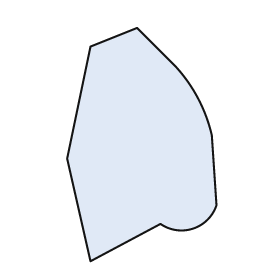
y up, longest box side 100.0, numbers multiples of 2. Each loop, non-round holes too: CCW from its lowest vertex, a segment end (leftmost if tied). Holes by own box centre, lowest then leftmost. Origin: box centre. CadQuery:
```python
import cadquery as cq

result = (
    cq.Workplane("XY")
    .moveTo(-22.0, -50.0)
    .lineTo(8.0, -34.0)
    .threePointArc((22.0, -36.0), (32.0, -26.0))
    .lineTo(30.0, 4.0)
    .threePointArc((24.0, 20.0), (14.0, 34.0))
    .lineTo(-2.0, 50.0)
    .lineTo(-22.0, 42.0)
    .lineTo(-32.0, -6.0)
    .close()
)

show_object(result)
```